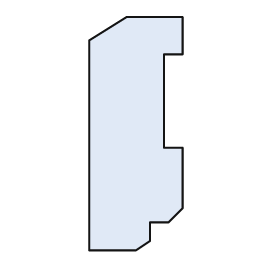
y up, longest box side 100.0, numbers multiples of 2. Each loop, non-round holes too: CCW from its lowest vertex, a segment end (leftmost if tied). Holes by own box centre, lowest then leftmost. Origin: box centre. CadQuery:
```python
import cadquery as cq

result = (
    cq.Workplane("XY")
    .moveTo(-20.0, -50.0)
    .lineTo(0.0, -50.0)
    .lineTo(6.0, -46.0)
    .lineTo(6.0, -38.0)
    .lineTo(14.0, -38.0)
    .lineTo(20.0, -32.0)
    .lineTo(20.0, -6.0)
    .lineTo(12.0, -6.0)
    .lineTo(12.0, 34.0)
    .lineTo(20.0, 34.0)
    .lineTo(20.0, 50.0)
    .lineTo(-4.0, 50.0)
    .lineTo(-20.0, 40.0)
    .close()
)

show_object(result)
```